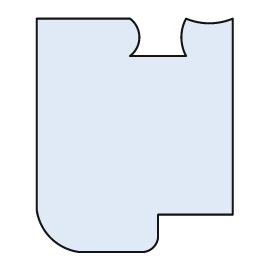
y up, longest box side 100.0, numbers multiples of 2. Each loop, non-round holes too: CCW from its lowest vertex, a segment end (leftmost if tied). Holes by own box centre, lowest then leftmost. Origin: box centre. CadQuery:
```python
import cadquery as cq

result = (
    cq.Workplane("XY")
    .moveTo(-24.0, -50.0)
    .lineTo(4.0, -50.0)
    .threePointArc((8.0, -48.0), (10.0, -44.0))
    .lineTo(10.0, -34.0)
    .lineTo(42.0, -34.0)
    .lineTo(42.0, 50.0)
    .threePointArc((32.0, 48.0), (22.0, 50.0))
    .threePointArc((20.0, 42.0), (22.0, 34.0))
    .lineTo(-2.0, 34.0)
    .threePointArc((2.0, 42.0), (-2.0, 50.0))
    .lineTo(-42.0, 50.0)
    .lineTo(-42.0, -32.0)
    .threePointArc((-36.0, -44.0), (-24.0, -50.0))
    .close()
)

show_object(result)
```